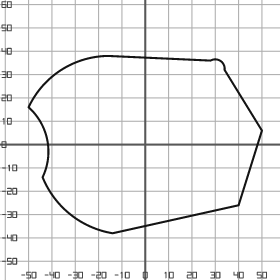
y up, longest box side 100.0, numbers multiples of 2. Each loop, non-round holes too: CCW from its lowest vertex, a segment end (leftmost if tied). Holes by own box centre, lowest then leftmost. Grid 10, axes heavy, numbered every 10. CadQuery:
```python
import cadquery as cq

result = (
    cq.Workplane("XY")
    .moveTo(-14.0, -38.0)
    .lineTo(40.0, -26.0)
    .lineTo(50.0, 6.0)
    .lineTo(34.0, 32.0)
    .threePointArc((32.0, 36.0), (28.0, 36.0))
    .lineTo(-16.0, 38.0)
    .threePointArc((-36.0, 32.0), (-50.0, 16.0))
    .threePointArc((-42.0, 2.0), (-44.0, -14.0))
    .threePointArc((-32.0, -30.0), (-14.0, -38.0))
    .close()
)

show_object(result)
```